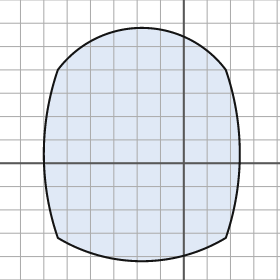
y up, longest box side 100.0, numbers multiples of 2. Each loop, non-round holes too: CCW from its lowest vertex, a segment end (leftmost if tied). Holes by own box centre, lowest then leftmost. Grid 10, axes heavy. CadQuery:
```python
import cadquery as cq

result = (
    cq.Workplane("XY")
    .moveTo(-54.0, -32.0)
    .threePointArc((-18.0, -42.0), (18.0, -32.0))
    .threePointArc((24.0, 4.0), (18.0, 40.0))
    .threePointArc((-18.0, 58.0), (-54.0, 40.0))
    .threePointArc((-60.0, 4.0), (-54.0, -32.0))
    .close()
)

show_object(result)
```